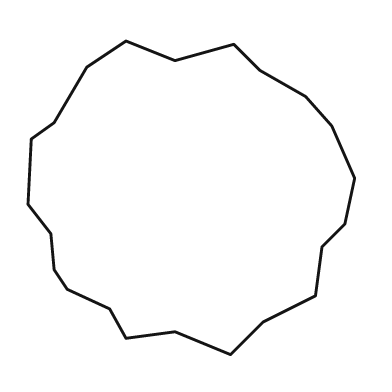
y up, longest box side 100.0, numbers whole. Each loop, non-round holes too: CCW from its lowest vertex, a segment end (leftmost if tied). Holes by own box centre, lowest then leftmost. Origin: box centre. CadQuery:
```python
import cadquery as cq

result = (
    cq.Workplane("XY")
    .moveTo(12.0, -48.0)
    .lineTo(22.0, -38.0)
    .lineTo(38.0, -30.0)
    .lineTo(40.0, -15.0)
    .lineTo(47.0, -8.0)
    .lineTo(50.0, 6.0)
    .lineTo(43.0, 22.0)
    .lineTo(35.0, 31.0)
    .lineTo(21.0, 39.0)
    .lineTo(13.0, 47.0)
    .lineTo(-5.0, 42.0)
    .lineTo(-20.0, 48.0)
    .lineTo(-32.0, 40.0)
    .lineTo(-42.0, 23.0)
    .lineTo(-49.0, 18.0)
    .lineTo(-50.0, -2.0)
    .lineTo(-43.0, -11.0)
    .lineTo(-42.0, -22.0)
    .lineTo(-38.0, -28.0)
    .lineTo(-25.0, -34.0)
    .lineTo(-20.0, -43.0)
    .lineTo(-5.0, -41.0)
    .close()
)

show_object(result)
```